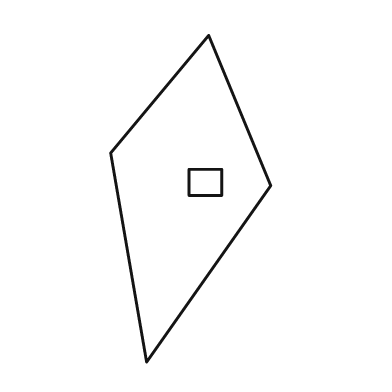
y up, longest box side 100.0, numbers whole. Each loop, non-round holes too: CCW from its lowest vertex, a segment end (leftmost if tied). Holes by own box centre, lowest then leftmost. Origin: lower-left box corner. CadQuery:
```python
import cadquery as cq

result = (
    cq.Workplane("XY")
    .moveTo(11.0, 0.0)
    .lineTo(49.0, 54.0)
    .lineTo(30.0, 100.0)
    .lineTo(0.0, 64.0)
    .close()
    .moveTo(24.0, 51.0)
    .lineTo(34.0, 51.0)
    .lineTo(34.0, 59.0)
    .lineTo(24.0, 59.0)
    .close()
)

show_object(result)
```